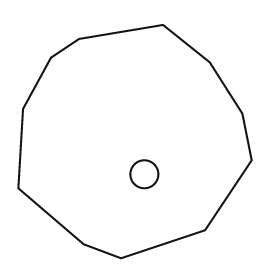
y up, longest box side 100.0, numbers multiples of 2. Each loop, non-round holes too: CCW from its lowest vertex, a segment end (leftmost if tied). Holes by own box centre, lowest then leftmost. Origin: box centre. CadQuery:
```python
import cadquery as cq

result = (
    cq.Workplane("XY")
    .moveTo(-6.0, -50.0)
    .lineTo(30.0, -38.0)
    .lineTo(50.0, -8.0)
    .lineTo(46.0, 12.0)
    .lineTo(32.0, 34.0)
    .lineTo(12.0, 50.0)
    .lineTo(-24.0, 44.0)
    .lineTo(-36.0, 36.0)
    .lineTo(-48.0, 14.0)
    .lineTo(-50.0, -20.0)
    .lineTo(-22.0, -44.0)
    .close()
    .moveTo(4.0, -14.0)
    .circle(6.0)
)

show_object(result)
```